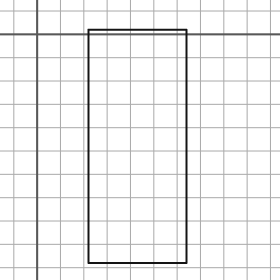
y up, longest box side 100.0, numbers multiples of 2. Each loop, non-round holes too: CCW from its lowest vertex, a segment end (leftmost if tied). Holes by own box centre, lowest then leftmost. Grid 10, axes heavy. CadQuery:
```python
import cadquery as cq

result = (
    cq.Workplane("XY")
    .moveTo(22.0, -98.0)
    .lineTo(64.0, -98.0)
    .lineTo(64.0, 2.0)
    .lineTo(22.0, 2.0)
    .close()
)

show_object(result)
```